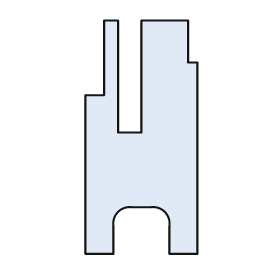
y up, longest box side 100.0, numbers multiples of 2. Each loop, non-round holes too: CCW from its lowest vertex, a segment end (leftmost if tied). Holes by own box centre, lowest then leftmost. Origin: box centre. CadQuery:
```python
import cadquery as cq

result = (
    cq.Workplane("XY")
    .moveTo(-24.0, -50.0)
    .lineTo(-12.0, -50.0)
    .lineTo(-12.0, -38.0)
    .threePointArc((-10.0, -32.0), (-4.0, -30.0))
    .lineTo(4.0, -30.0)
    .threePointArc((10.0, -32.0), (12.0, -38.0))
    .lineTo(12.0, -50.0)
    .lineTo(24.0, -50.0)
    .lineTo(24.0, 32.0)
    .lineTo(20.0, 32.0)
    .lineTo(20.0, 50.0)
    .lineTo(0.0, 50.0)
    .lineTo(0.0, 2.0)
    .lineTo(-10.0, 2.0)
    .lineTo(-10.0, 50.0)
    .lineTo(-16.0, 50.0)
    .lineTo(-16.0, 18.0)
    .lineTo(-24.0, 18.0)
    .close()
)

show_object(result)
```